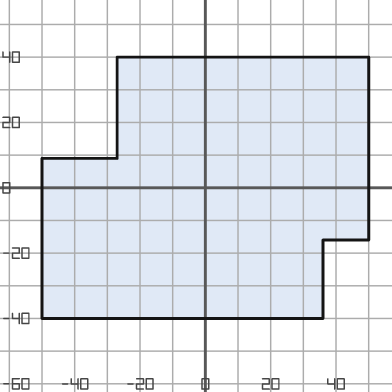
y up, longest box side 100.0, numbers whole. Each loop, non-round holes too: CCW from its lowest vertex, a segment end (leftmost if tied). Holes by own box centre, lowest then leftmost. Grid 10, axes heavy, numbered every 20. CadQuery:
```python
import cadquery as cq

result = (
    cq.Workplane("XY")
    .moveTo(-50.0, -40.0)
    .lineTo(36.0, -40.0)
    .lineTo(36.0, -16.0)
    .lineTo(50.0, -16.0)
    .lineTo(50.0, 40.0)
    .lineTo(-27.0, 40.0)
    .lineTo(-27.0, 9.0)
    .lineTo(-50.0, 9.0)
    .close()
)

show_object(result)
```